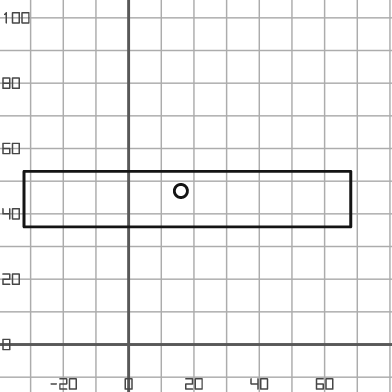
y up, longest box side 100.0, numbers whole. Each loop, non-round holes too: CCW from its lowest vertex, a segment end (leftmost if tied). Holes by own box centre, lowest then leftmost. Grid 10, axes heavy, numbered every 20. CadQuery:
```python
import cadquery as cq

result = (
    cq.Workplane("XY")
    .moveTo(-32.0, 36.0)
    .lineTo(68.0, 36.0)
    .lineTo(68.0, 53.0)
    .lineTo(-32.0, 53.0)
    .close()
    .moveTo(16.0, 47.0)
    .circle(2.0)
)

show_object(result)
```